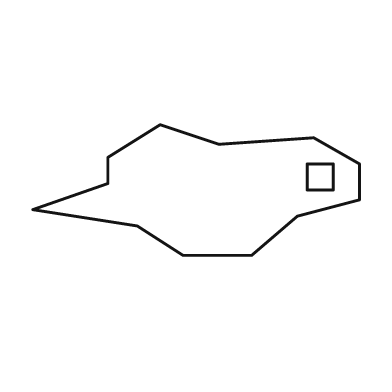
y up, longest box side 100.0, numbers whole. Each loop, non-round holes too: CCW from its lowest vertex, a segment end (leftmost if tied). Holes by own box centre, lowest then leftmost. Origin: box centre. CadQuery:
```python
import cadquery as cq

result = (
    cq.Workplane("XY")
    .moveTo(-4.0, -20.0)
    .lineTo(17.0, -20.0)
    .lineTo(31.0, -8.0)
    .lineTo(50.0, -3.0)
    .lineTo(50.0, 8.0)
    .lineTo(36.0, 16.0)
    .lineTo(7.0, 14.0)
    .lineTo(-11.0, 20.0)
    .lineTo(-27.0, 10.0)
    .lineTo(-27.0, 2.0)
    .lineTo(-50.0, -6.0)
    .lineTo(-18.0, -11.0)
    .close()
    .moveTo(34.0, 0.0)
    .lineTo(42.0, 0.0)
    .lineTo(42.0, 8.0)
    .lineTo(34.0, 8.0)
    .close()
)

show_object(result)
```